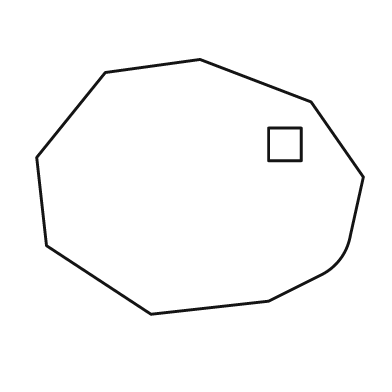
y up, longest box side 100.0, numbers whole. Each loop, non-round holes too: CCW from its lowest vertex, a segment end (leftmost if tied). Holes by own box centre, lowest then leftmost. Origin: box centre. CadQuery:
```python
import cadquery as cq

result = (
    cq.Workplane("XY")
    .moveTo(-15.0, -39.0)
    .lineTo(21.0, -35.0)
    .lineTo(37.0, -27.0)
    .threePointArc((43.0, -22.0), (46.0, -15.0))
    .lineTo(50.0, 3.0)
    .lineTo(34.0, 26.0)
    .lineTo(0.0, 39.0)
    .lineTo(-29.0, 35.0)
    .lineTo(-50.0, 9.0)
    .lineTo(-47.0, -18.0)
    .close()
    .moveTo(21.0, 8.0)
    .lineTo(31.0, 8.0)
    .lineTo(31.0, 18.0)
    .lineTo(21.0, 18.0)
    .close()
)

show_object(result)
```